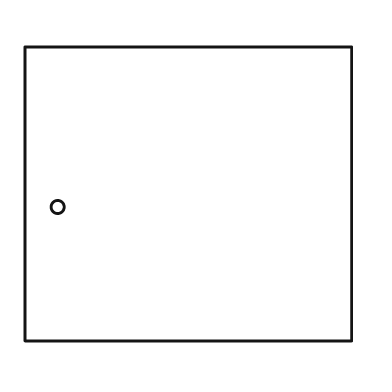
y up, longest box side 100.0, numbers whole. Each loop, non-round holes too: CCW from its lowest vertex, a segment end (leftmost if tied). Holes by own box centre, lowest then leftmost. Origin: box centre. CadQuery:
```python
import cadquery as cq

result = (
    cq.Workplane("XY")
    .moveTo(-50.0, -45.0)
    .lineTo(50.0, -45.0)
    .lineTo(50.0, 45.0)
    .lineTo(-50.0, 45.0)
    .close()
    .moveTo(-40.0, -4.0)
    .circle(2.0)
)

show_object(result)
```